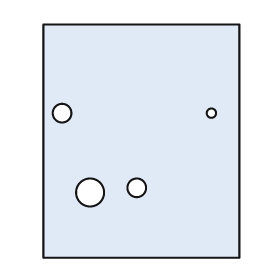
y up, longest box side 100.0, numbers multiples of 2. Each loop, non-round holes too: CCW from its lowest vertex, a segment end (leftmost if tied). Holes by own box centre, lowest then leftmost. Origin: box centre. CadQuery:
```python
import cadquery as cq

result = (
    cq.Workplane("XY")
    .moveTo(-42.0, -50.0)
    .lineTo(42.0, -50.0)
    .lineTo(42.0, 50.0)
    .lineTo(-42.0, 50.0)
    .close()
    .moveTo(-22.0, -22.0)
    .circle(6.0)
    .moveTo(-2.0, -20.0)
    .circle(4.0)
    .moveTo(-34.0, 12.0)
    .circle(4.0)
    .moveTo(30.0, 12.0)
    .circle(2.0)
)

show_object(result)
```